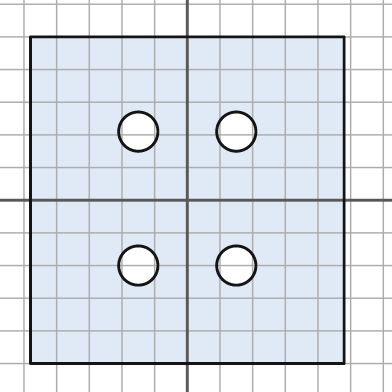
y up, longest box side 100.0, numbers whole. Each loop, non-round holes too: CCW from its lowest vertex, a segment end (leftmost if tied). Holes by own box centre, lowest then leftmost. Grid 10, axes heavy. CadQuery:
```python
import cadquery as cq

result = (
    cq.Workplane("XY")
    .moveTo(-48.0, -50.0)
    .lineTo(48.0, -50.0)
    .lineTo(48.0, 50.0)
    .lineTo(-48.0, 50.0)
    .close()
    .moveTo(-15.0, -20.0)
    .circle(6.0)
    .moveTo(15.0, -20.0)
    .circle(6.0)
    .moveTo(-15.0, 21.0)
    .circle(6.0)
    .moveTo(15.0, 21.0)
    .circle(6.0)
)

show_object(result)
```